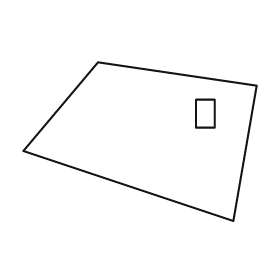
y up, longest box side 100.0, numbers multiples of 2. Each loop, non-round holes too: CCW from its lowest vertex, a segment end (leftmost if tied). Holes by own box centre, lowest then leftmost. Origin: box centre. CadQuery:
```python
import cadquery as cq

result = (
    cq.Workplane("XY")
    .moveTo(40.0, -34.0)
    .lineTo(50.0, 24.0)
    .lineTo(-18.0, 34.0)
    .lineTo(-50.0, -4.0)
    .close()
    .moveTo(24.0, 6.0)
    .lineTo(32.0, 6.0)
    .lineTo(32.0, 18.0)
    .lineTo(24.0, 18.0)
    .close()
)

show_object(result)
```